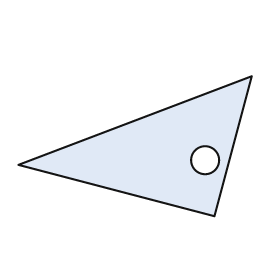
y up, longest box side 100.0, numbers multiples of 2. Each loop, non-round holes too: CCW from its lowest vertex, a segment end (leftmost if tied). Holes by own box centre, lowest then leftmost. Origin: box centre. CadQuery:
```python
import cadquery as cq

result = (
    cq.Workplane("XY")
    .moveTo(34.0, -30.0)
    .lineTo(50.0, 30.0)
    .lineTo(-50.0, -8.0)
    .close()
    .moveTo(30.0, -6.0)
    .circle(6.0)
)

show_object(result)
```